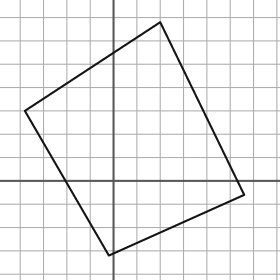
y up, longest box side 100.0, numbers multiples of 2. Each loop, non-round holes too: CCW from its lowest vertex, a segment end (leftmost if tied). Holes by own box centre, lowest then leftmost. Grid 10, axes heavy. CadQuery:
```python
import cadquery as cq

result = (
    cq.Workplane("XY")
    .moveTo(-2.0, -32.0)
    .lineTo(56.0, -6.0)
    .lineTo(20.0, 68.0)
    .lineTo(-38.0, 30.0)
    .close()
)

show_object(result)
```